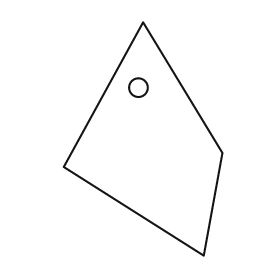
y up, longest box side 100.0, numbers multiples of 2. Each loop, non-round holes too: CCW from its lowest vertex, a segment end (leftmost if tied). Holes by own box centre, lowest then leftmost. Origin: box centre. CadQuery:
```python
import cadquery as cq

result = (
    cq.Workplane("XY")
    .moveTo(26.0, -50.0)
    .lineTo(34.0, -6.0)
    .lineTo(0.0, 50.0)
    .lineTo(-34.0, -12.0)
    .close()
    .moveTo(-2.0, 22.0)
    .circle(4.0)
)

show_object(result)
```